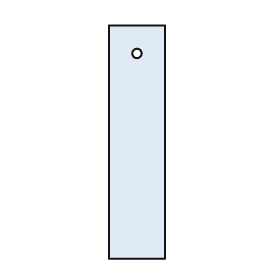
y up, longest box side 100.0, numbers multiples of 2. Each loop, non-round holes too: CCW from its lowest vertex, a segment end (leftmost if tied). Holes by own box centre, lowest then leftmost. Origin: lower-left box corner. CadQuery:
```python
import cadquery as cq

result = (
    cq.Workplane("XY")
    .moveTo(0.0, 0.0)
    .lineTo(24.0, 0.0)
    .lineTo(24.0, 100.0)
    .lineTo(0.0, 100.0)
    .close()
    .moveTo(12.0, 88.0)
    .circle(2.0)
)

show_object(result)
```